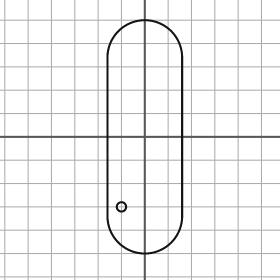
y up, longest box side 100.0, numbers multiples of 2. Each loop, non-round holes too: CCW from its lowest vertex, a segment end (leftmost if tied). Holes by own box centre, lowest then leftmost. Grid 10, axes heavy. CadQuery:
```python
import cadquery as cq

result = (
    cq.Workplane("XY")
    .moveTo(-16.0, -34.0)
    .threePointArc((0.0, -50.0), (16.0, -34.0))
    .lineTo(16.0, 34.0)
    .threePointArc((0.0, 50.0), (-16.0, 34.0))
    .close()
    .moveTo(-10.0, -30.0)
    .circle(2.0)
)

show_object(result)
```